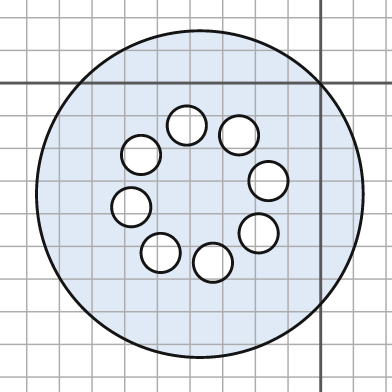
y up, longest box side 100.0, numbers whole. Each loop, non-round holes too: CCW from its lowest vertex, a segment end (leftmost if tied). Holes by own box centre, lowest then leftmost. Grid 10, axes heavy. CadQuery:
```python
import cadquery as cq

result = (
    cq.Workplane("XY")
    .moveTo(-37.0, -34.0)
    .circle(50.0)
    .moveTo(-33.0, -55.0)
    .circle(6.0)
    .moveTo(-49.0, -52.0)
    .circle(6.0)
    .moveTo(-19.0, -46.0)
    .circle(6.0)
    .moveTo(-58.0, -38.0)
    .circle(6.0)
    .moveTo(-16.0, -30.0)
    .circle(6.0)
    .moveTo(-55.0, -22.0)
    .circle(6.0)
    .moveTo(-25.0, -16.0)
    .circle(6.0)
    .moveTo(-41.0, -13.0)
    .circle(6.0)
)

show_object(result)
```